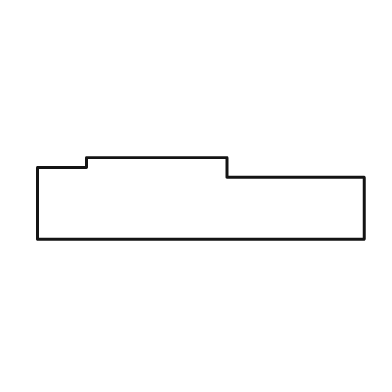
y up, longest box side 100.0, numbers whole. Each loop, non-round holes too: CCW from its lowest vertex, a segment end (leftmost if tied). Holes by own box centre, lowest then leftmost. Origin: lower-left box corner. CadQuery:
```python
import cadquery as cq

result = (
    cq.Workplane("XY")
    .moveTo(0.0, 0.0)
    .lineTo(100.0, 0.0)
    .lineTo(100.0, 19.0)
    .lineTo(58.0, 19.0)
    .lineTo(58.0, 25.0)
    .lineTo(15.0, 25.0)
    .lineTo(15.0, 22.0)
    .lineTo(0.0, 22.0)
    .close()
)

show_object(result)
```